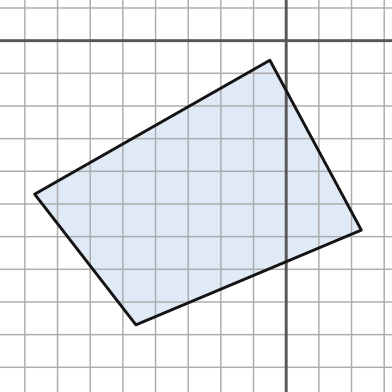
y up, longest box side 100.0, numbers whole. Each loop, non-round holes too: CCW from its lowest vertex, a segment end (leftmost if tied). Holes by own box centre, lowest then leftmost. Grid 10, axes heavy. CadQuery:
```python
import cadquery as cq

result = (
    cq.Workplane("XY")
    .moveTo(-46.0, -87.0)
    .lineTo(23.0, -58.0)
    .lineTo(-5.0, -6.0)
    .lineTo(-77.0, -47.0)
    .close()
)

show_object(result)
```